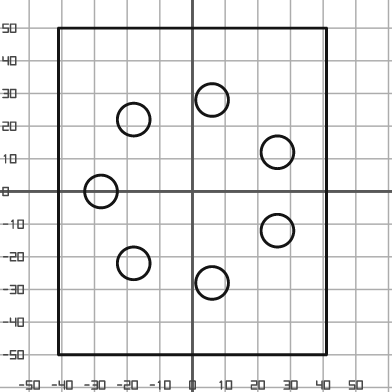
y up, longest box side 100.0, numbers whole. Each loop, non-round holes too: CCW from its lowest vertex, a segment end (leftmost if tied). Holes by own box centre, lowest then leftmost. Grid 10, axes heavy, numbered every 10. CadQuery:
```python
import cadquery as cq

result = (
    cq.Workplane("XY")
    .moveTo(-41.0, -50.0)
    .lineTo(41.0, -50.0)
    .lineTo(41.0, 50.0)
    .lineTo(-41.0, 50.0)
    .close()
    .moveTo(6.0, -28.0)
    .circle(5.0)
    .moveTo(-18.0, -22.0)
    .circle(5.0)
    .moveTo(26.0, -12.0)
    .circle(5.0)
    .moveTo(-28.0, 0.0)
    .circle(5.0)
    .moveTo(26.0, 12.0)
    .circle(5.0)
    .moveTo(-18.0, 22.0)
    .circle(5.0)
    .moveTo(6.0, 28.0)
    .circle(5.0)
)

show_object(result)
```